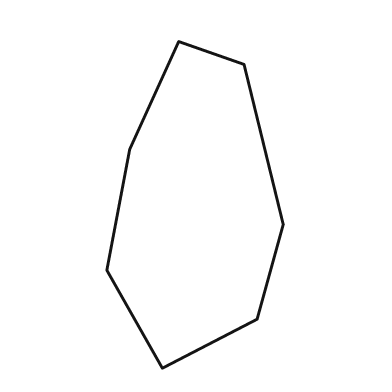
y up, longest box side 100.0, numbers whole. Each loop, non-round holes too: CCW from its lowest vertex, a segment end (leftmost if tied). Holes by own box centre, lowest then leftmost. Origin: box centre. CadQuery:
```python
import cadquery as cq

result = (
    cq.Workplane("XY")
    .moveTo(-10.0, -50.0)
    .lineTo(19.0, -35.0)
    .lineTo(27.0, -6.0)
    .lineTo(15.0, 43.0)
    .lineTo(-5.0, 50.0)
    .lineTo(-20.0, 17.0)
    .lineTo(-27.0, -20.0)
    .close()
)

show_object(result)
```